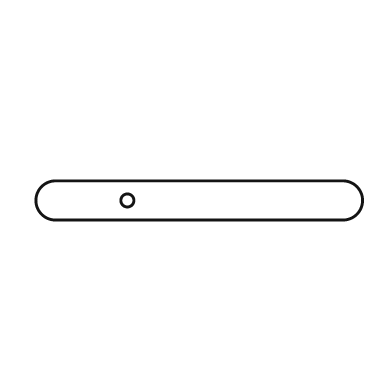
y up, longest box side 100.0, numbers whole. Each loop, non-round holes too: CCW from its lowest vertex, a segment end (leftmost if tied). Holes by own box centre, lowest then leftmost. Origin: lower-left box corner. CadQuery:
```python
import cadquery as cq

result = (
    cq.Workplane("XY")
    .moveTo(6.0, 0.0)
    .lineTo(94.0, 0.0)
    .threePointArc((100.0, 6.0), (94.0, 12.0))
    .lineTo(6.0, 12.0)
    .threePointArc((0.0, 6.0), (6.0, 0.0))
    .close()
    .moveTo(28.0, 6.0)
    .circle(2.0)
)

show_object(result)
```